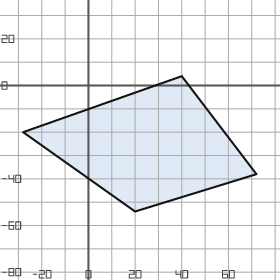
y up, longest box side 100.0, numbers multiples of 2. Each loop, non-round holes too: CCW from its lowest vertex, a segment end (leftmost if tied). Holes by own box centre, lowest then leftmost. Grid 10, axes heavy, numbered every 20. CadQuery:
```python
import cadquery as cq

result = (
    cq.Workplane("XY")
    .moveTo(20.0, -54.0)
    .lineTo(72.0, -38.0)
    .lineTo(40.0, 4.0)
    .lineTo(-28.0, -20.0)
    .close()
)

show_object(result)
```